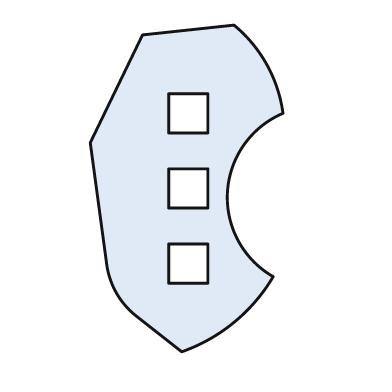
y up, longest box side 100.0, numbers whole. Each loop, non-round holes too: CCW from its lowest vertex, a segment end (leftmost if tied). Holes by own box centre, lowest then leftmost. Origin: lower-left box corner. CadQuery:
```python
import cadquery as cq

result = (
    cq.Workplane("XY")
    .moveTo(28.0, 0.0)
    .threePointArc((44.0, 9.0), (56.0, 23.0))
    .threePointArc((42.0, 49.0), (59.0, 73.0))
    .threePointArc((54.0, 88.0), (44.0, 100.0))
    .lineTo(16.0, 97.0)
    .lineTo(0.0, 64.0)
    .lineTo(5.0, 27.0)
    .threePointArc((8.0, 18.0), (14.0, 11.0))
    .close()
    .moveTo(24.0, 21.0)
    .lineTo(36.0, 21.0)
    .lineTo(36.0, 33.0)
    .lineTo(24.0, 33.0)
    .close()
    .moveTo(24.0, 44.0)
    .lineTo(36.0, 44.0)
    .lineTo(36.0, 56.0)
    .lineTo(24.0, 56.0)
    .close()
    .moveTo(24.0, 67.0)
    .lineTo(36.0, 67.0)
    .lineTo(36.0, 79.0)
    .lineTo(24.0, 79.0)
    .close()
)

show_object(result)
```